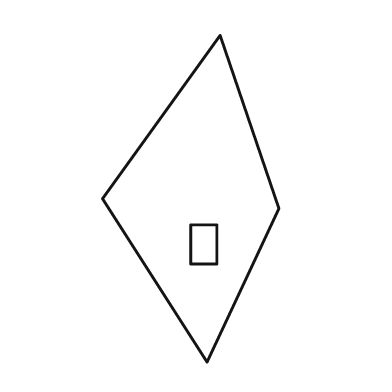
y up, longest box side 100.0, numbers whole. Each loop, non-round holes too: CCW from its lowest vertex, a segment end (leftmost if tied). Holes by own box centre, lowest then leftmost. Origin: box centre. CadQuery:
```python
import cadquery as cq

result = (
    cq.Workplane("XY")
    .moveTo(5.0, -50.0)
    .lineTo(27.0, -3.0)
    .lineTo(9.0, 50.0)
    .lineTo(-27.0, 0.0)
    .close()
    .moveTo(0.0, -20.0)
    .lineTo(8.0, -20.0)
    .lineTo(8.0, -8.0)
    .lineTo(0.0, -8.0)
    .close()
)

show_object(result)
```